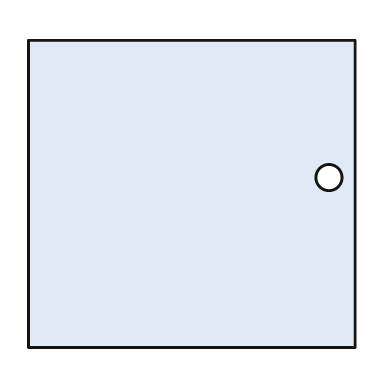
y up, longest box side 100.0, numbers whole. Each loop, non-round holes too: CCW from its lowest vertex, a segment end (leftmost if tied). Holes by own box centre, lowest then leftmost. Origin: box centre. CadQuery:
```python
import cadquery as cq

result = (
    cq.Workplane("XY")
    .moveTo(-50.0, -47.0)
    .lineTo(50.0, -47.0)
    .lineTo(50.0, 47.0)
    .lineTo(-50.0, 47.0)
    .close()
    .moveTo(42.0, 5.0)
    .circle(4.0)
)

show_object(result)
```